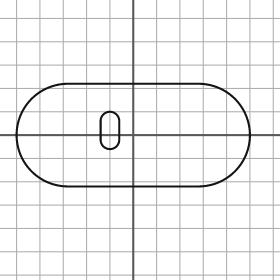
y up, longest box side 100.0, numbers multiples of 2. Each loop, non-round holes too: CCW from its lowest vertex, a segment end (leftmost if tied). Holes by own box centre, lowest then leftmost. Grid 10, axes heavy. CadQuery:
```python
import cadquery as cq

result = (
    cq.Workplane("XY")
    .moveTo(-28.0, -22.0)
    .lineTo(28.0, -22.0)
    .threePointArc((50.0, 0.0), (28.0, 22.0))
    .lineTo(-28.0, 22.0)
    .threePointArc((-50.0, 0.0), (-28.0, -22.0))
    .close()
    .moveTo(-14.0, -2.0)
    .threePointArc((-10.0, -6.0), (-6.0, -2.0))
    .lineTo(-6.0, 6.0)
    .threePointArc((-10.0, 10.0), (-14.0, 6.0))
    .close()
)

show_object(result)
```